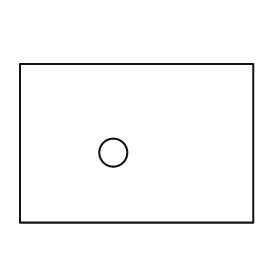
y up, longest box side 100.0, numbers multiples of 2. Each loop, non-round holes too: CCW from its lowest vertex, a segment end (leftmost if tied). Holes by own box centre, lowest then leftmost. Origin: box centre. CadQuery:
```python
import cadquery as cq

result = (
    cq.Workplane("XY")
    .moveTo(-50.0, -34.0)
    .lineTo(50.0, -34.0)
    .lineTo(50.0, 34.0)
    .lineTo(-50.0, 34.0)
    .close()
    .moveTo(-10.0, -4.0)
    .circle(6.0)
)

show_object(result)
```